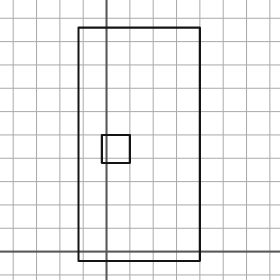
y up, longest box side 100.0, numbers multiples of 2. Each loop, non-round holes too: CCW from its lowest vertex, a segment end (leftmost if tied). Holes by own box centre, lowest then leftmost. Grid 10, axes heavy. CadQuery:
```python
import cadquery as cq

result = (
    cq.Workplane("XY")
    .moveTo(-12.0, -4.0)
    .lineTo(40.0, -4.0)
    .lineTo(40.0, 96.0)
    .lineTo(-12.0, 96.0)
    .close()
    .moveTo(-2.0, 38.0)
    .lineTo(10.0, 38.0)
    .lineTo(10.0, 50.0)
    .lineTo(-2.0, 50.0)
    .close()
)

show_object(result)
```